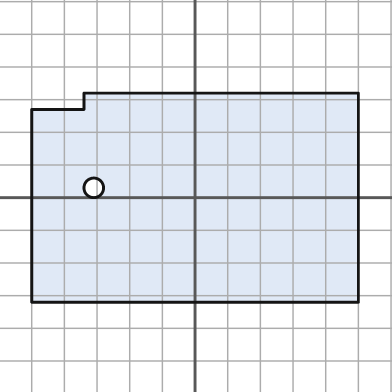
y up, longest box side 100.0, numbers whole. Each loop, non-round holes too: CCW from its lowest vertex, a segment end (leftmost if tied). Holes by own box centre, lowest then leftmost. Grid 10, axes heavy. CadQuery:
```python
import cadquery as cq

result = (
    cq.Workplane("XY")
    .moveTo(-50.0, -32.0)
    .lineTo(50.0, -32.0)
    .lineTo(50.0, 32.0)
    .lineTo(-34.0, 32.0)
    .lineTo(-34.0, 27.0)
    .lineTo(-50.0, 27.0)
    .close()
    .moveTo(-31.0, 3.0)
    .circle(3.0)
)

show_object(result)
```